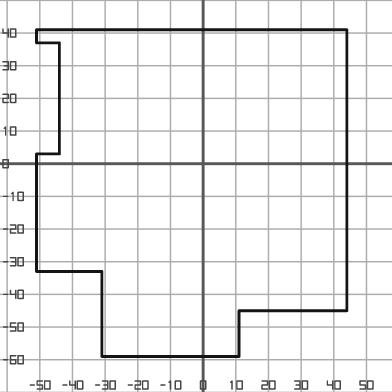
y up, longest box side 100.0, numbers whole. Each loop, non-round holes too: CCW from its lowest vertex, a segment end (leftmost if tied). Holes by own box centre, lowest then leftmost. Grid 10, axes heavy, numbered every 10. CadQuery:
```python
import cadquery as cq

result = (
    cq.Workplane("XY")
    .moveTo(-31.0, -59.0)
    .lineTo(11.0, -59.0)
    .lineTo(11.0, -45.0)
    .lineTo(44.0, -45.0)
    .lineTo(44.0, 41.0)
    .lineTo(-51.0, 41.0)
    .lineTo(-51.0, 37.0)
    .lineTo(-44.0, 37.0)
    .lineTo(-44.0, 3.0)
    .lineTo(-51.0, 3.0)
    .lineTo(-51.0, -33.0)
    .lineTo(-31.0, -33.0)
    .close()
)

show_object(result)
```